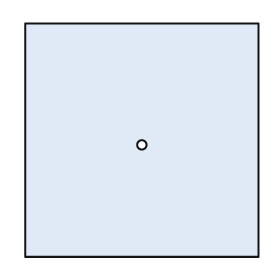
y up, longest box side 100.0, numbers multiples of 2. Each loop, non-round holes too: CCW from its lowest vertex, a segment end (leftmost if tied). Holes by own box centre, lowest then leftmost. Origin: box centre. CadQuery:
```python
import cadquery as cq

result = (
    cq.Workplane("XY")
    .moveTo(-50.0, -50.0)
    .lineTo(50.0, -50.0)
    .lineTo(50.0, 50.0)
    .lineTo(-50.0, 50.0)
    .close()
    .moveTo(0.0, -2.0)
    .circle(2.0)
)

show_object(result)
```